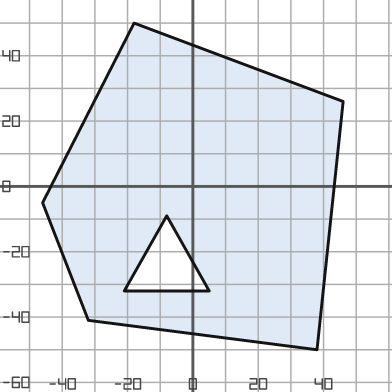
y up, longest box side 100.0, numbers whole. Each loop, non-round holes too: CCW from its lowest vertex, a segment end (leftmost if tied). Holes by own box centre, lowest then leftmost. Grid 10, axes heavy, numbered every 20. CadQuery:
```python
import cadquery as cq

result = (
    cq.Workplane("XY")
    .moveTo(38.0, -50.0)
    .lineTo(46.0, 26.0)
    .lineTo(-18.0, 50.0)
    .lineTo(-46.0, -5.0)
    .lineTo(-32.0, -41.0)
    .close()
    .moveTo(-21.0, -32.0)
    .lineTo(5.0, -32.0)
    .lineTo(-8.0, -9.0)
    .close()
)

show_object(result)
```